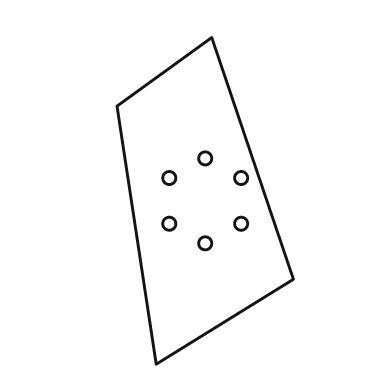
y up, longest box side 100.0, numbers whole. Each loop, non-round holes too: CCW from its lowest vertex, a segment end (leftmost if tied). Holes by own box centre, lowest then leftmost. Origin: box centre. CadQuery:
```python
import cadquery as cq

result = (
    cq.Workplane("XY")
    .moveTo(-15.0, -50.0)
    .lineTo(27.0, -24.0)
    .lineTo(2.0, 50.0)
    .lineTo(-27.0, 29.0)
    .close()
    .moveTo(0.0, -13.0)
    .circle(2.0)
    .moveTo(-11.0, -7.0)
    .circle(2.0)
    .moveTo(11.0, -7.0)
    .circle(2.0)
    .moveTo(-11.0, 7.0)
    .circle(2.0)
    .moveTo(11.0, 7.0)
    .circle(2.0)
    .moveTo(0.0, 13.0)
    .circle(2.0)
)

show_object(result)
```